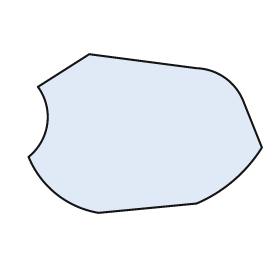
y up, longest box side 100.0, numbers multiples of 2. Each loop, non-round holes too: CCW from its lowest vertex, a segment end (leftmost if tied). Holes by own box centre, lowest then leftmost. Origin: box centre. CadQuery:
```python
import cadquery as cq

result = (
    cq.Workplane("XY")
    .moveTo(-20.0, -34.0)
    .lineTo(22.0, -30.0)
    .threePointArc((38.0, -20.0), (50.0, -6.0))
    .lineTo(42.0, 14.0)
    .threePointArc((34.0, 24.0), (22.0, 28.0))
    .lineTo(-24.0, 34.0)
    .lineTo(-46.0, 20.0)
    .threePointArc((-42.0, 4.0), (-50.0, -10.0))
    .threePointArc((-38.0, -26.0), (-20.0, -34.0))
    .close()
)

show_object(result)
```